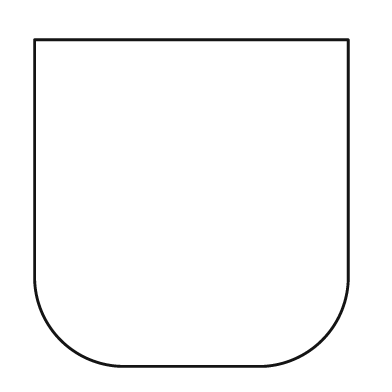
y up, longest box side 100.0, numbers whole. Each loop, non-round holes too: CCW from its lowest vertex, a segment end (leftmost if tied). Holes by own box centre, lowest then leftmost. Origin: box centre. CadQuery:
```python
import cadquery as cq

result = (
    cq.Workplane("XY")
    .moveTo(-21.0, -50.0)
    .lineTo(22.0, -50.0)
    .threePointArc((40.0, -42.0), (48.0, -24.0))
    .lineTo(48.0, 50.0)
    .lineTo(-48.0, 50.0)
    .lineTo(-48.0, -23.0)
    .threePointArc((-40.0, -42.0), (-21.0, -50.0))
    .close()
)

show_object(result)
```